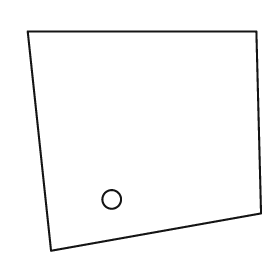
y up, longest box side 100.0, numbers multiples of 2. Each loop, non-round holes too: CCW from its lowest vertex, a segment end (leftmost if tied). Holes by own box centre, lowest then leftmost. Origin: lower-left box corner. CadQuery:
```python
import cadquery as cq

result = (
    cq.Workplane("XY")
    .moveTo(10.0, 0.0)
    .lineTo(100.0, 16.0)
    .lineTo(98.0, 94.0)
    .lineTo(0.0, 94.0)
    .close()
    .moveTo(36.0, 22.0)
    .circle(4.0)
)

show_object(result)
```